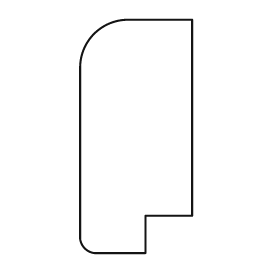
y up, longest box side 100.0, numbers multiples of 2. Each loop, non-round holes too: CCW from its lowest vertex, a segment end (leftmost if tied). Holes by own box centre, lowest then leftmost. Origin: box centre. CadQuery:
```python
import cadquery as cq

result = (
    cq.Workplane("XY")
    .moveTo(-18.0, -50.0)
    .lineTo(4.0, -50.0)
    .lineTo(4.0, -34.0)
    .lineTo(24.0, -34.0)
    .lineTo(24.0, 50.0)
    .lineTo(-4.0, 50.0)
    .threePointArc((-18.0, 44.0), (-24.0, 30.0))
    .lineTo(-24.0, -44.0)
    .threePointArc((-22.0, -48.0), (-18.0, -50.0))
    .close()
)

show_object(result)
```